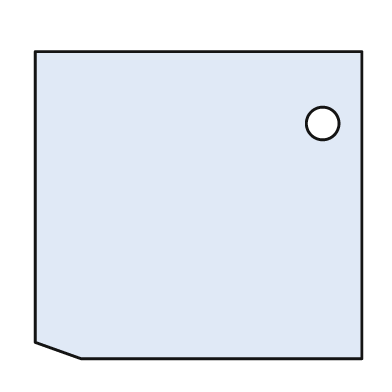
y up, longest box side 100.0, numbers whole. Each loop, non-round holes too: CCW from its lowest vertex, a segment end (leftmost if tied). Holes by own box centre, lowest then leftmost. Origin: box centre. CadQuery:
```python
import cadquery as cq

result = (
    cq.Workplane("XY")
    .moveTo(-36.0, -47.0)
    .lineTo(50.0, -47.0)
    .lineTo(50.0, 47.0)
    .lineTo(-50.0, 47.0)
    .lineTo(-50.0, -42.0)
    .close()
    .moveTo(38.0, 25.0)
    .circle(5.0)
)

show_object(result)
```